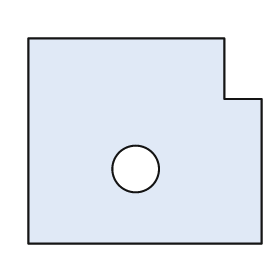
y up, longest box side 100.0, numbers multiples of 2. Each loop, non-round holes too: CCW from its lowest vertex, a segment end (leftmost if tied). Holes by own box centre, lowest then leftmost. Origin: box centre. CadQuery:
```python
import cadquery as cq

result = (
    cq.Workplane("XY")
    .moveTo(-50.0, -44.0)
    .lineTo(50.0, -44.0)
    .lineTo(50.0, 18.0)
    .lineTo(34.0, 18.0)
    .lineTo(34.0, 44.0)
    .lineTo(-50.0, 44.0)
    .close()
    .moveTo(-4.0, -12.0)
    .circle(10.0)
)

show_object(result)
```